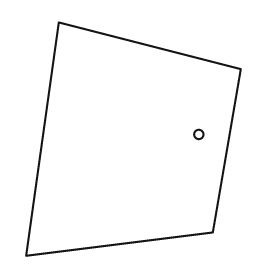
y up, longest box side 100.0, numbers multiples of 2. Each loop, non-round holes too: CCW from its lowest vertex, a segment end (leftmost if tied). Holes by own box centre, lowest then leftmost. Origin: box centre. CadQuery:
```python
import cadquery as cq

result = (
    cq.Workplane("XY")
    .moveTo(-46.0, -50.0)
    .lineTo(34.0, -40.0)
    .lineTo(46.0, 30.0)
    .lineTo(-32.0, 50.0)
    .close()
    .moveTo(28.0, 2.0)
    .circle(2.0)
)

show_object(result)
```